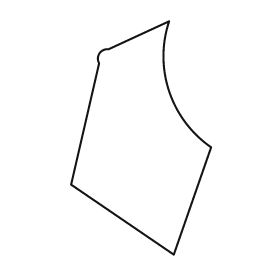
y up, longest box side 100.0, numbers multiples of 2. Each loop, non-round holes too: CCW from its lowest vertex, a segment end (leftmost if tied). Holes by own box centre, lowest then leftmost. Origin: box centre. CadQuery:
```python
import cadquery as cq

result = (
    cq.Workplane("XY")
    .moveTo(14.0, -50.0)
    .lineTo(30.0, -4.0)
    .threePointArc((12.0, 20.0), (12.0, 50.0))
    .lineTo(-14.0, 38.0)
    .threePointArc((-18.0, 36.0), (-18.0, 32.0))
    .lineTo(-30.0, -20.0)
    .close()
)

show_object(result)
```